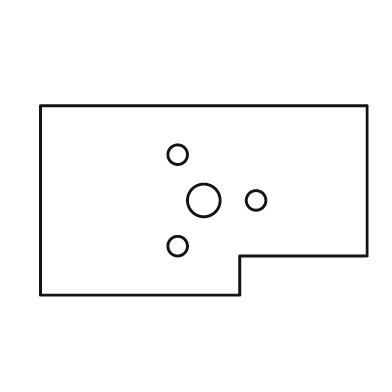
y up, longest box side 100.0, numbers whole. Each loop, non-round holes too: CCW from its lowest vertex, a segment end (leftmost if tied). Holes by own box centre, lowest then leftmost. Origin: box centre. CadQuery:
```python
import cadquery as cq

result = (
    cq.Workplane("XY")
    .moveTo(-50.0, -29.0)
    .lineTo(11.0, -29.0)
    .lineTo(11.0, -17.0)
    .lineTo(50.0, -17.0)
    .lineTo(50.0, 29.0)
    .lineTo(-50.0, 29.0)
    .close()
    .moveTo(-8.0, -14.0)
    .circle(3.0)
    .moveTo(0.0, 0.0)
    .circle(5.0)
    .moveTo(16.0, 0.0)
    .circle(3.0)
    .moveTo(-8.0, 14.0)
    .circle(3.0)
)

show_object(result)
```